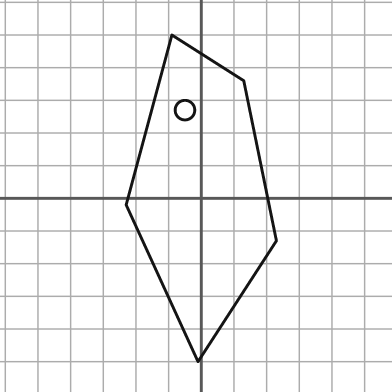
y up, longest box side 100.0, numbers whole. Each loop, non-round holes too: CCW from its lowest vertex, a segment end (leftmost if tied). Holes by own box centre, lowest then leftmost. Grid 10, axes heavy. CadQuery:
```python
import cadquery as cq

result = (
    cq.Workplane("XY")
    .moveTo(-1.0, -50.0)
    .lineTo(23.0, -13.0)
    .lineTo(13.0, 36.0)
    .lineTo(-9.0, 50.0)
    .lineTo(-23.0, -2.0)
    .close()
    .moveTo(-5.0, 27.0)
    .circle(3.0)
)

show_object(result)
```